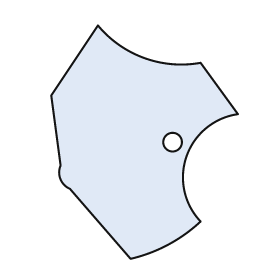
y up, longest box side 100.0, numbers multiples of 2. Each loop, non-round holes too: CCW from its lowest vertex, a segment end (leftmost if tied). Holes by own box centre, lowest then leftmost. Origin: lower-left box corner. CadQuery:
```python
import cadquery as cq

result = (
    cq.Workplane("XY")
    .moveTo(34.0, 0.0)
    .threePointArc((50.0, 6.0), (64.0, 16.0))
    .threePointArc((58.0, 44.0), (80.0, 62.0))
    .lineTo(64.0, 84.0)
    .threePointArc((40.0, 86.0), (20.0, 100.0))
    .lineTo(0.0, 70.0)
    .lineTo(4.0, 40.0)
    .threePointArc((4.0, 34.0), (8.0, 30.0))
    .close()
    .moveTo(52.0, 50.0)
    .circle(4.0)
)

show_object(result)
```